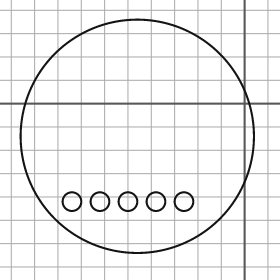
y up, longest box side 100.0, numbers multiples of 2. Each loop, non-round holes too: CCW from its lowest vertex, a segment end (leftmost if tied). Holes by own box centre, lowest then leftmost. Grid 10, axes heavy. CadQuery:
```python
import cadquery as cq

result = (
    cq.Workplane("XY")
    .moveTo(-46.0, -14.0)
    .circle(50.0)
    .moveTo(-74.0, -42.0)
    .circle(4.0)
    .moveTo(-62.0, -42.0)
    .circle(4.0)
    .moveTo(-50.0, -42.0)
    .circle(4.0)
    .moveTo(-38.0, -42.0)
    .circle(4.0)
    .moveTo(-26.0, -42.0)
    .circle(4.0)
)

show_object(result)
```